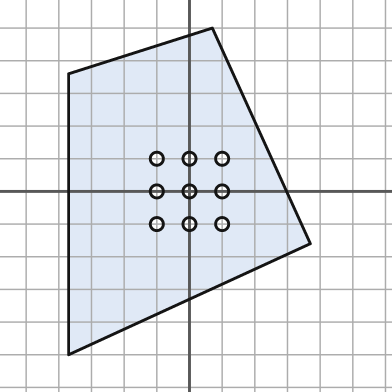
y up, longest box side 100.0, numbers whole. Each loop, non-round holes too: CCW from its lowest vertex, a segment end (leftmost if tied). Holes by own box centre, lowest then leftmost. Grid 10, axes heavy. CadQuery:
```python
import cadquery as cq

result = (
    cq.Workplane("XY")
    .moveTo(-37.0, -50.0)
    .lineTo(37.0, -16.0)
    .lineTo(7.0, 50.0)
    .lineTo(-37.0, 36.0)
    .close()
    .moveTo(-10.0, -10.0)
    .circle(2.0)
    .moveTo(0.0, -10.0)
    .circle(2.0)
    .moveTo(10.0, -10.0)
    .circle(2.0)
    .moveTo(-10.0, 0.0)
    .circle(2.0)
    .moveTo(0.0, 0.0)
    .circle(2.0)
    .moveTo(10.0, 0.0)
    .circle(2.0)
    .moveTo(-10.0, 10.0)
    .circle(2.0)
    .moveTo(0.0, 10.0)
    .circle(2.0)
    .moveTo(10.0, 10.0)
    .circle(2.0)
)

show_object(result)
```